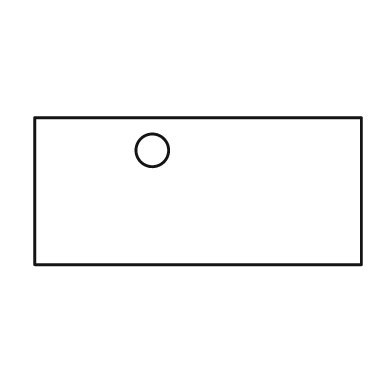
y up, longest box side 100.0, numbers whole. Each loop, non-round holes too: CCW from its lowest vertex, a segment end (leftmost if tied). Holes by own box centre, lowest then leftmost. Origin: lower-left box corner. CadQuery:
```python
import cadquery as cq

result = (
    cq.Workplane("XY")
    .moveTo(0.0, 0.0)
    .lineTo(100.0, 0.0)
    .lineTo(100.0, 45.0)
    .lineTo(0.0, 45.0)
    .close()
    .moveTo(36.0, 35.0)
    .circle(5.0)
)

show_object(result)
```